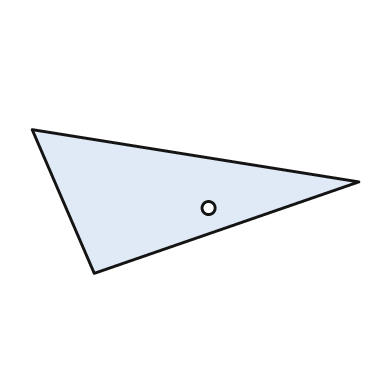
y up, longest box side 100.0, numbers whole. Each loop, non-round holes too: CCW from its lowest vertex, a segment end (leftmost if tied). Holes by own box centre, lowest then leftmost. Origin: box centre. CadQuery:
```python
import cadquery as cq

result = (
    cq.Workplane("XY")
    .moveTo(-31.0, -22.0)
    .lineTo(50.0, 6.0)
    .lineTo(-50.0, 22.0)
    .close()
    .moveTo(4.0, -2.0)
    .circle(2.0)
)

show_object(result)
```